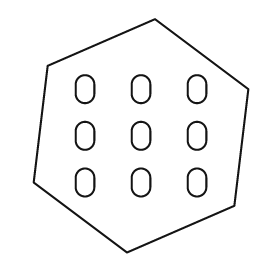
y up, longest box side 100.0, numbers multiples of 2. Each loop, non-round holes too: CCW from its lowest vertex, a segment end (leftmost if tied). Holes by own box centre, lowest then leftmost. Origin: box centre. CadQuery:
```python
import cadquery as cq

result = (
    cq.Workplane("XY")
    .moveTo(-6.0, -50.0)
    .lineTo(40.0, -30.0)
    .lineTo(46.0, 20.0)
    .lineTo(6.0, 50.0)
    .lineTo(-40.0, 30.0)
    .lineTo(-46.0, -20.0)
    .close()
    .moveTo(-28.0, -22.0)
    .threePointArc((-24.0, -26.0), (-20.0, -22.0))
    .lineTo(-20.0, -18.0)
    .threePointArc((-24.0, -14.0), (-28.0, -18.0))
    .close()
    .moveTo(-4.0, -22.0)
    .threePointArc((0.0, -26.0), (4.0, -22.0))
    .lineTo(4.0, -18.0)
    .threePointArc((0.0, -14.0), (-4.0, -18.0))
    .close()
    .moveTo(20.0, -22.0)
    .threePointArc((24.0, -26.0), (28.0, -22.0))
    .lineTo(28.0, -18.0)
    .threePointArc((24.0, -14.0), (20.0, -18.0))
    .close()
    .moveTo(-28.0, -2.0)
    .threePointArc((-24.0, -6.0), (-20.0, -2.0))
    .lineTo(-20.0, 2.0)
    .threePointArc((-24.0, 6.0), (-28.0, 2.0))
    .close()
    .moveTo(-4.0, -2.0)
    .threePointArc((0.0, -6.0), (4.0, -2.0))
    .lineTo(4.0, 2.0)
    .threePointArc((0.0, 6.0), (-4.0, 2.0))
    .close()
    .moveTo(20.0, -2.0)
    .threePointArc((24.0, -6.0), (28.0, -2.0))
    .lineTo(28.0, 2.0)
    .threePointArc((24.0, 6.0), (20.0, 2.0))
    .close()
    .moveTo(-28.0, 18.0)
    .threePointArc((-24.0, 14.0), (-20.0, 18.0))
    .lineTo(-20.0, 22.0)
    .threePointArc((-24.0, 26.0), (-28.0, 22.0))
    .close()
    .moveTo(-4.0, 18.0)
    .threePointArc((0.0, 14.0), (4.0, 18.0))
    .lineTo(4.0, 22.0)
    .threePointArc((0.0, 26.0), (-4.0, 22.0))
    .close()
    .moveTo(20.0, 18.0)
    .threePointArc((24.0, 14.0), (28.0, 18.0))
    .lineTo(28.0, 22.0)
    .threePointArc((24.0, 26.0), (20.0, 22.0))
    .close()
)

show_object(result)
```